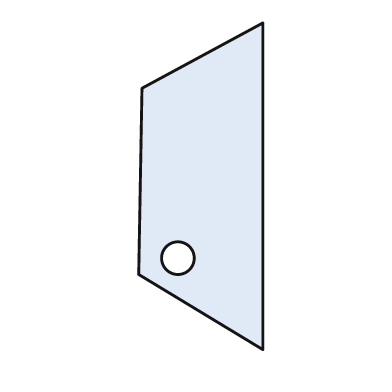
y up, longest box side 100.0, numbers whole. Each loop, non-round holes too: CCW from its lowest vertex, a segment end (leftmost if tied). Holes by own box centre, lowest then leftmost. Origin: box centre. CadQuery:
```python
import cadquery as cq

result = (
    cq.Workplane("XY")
    .moveTo(19.0, -50.0)
    .lineTo(19.0, 50.0)
    .lineTo(-18.0, 30.0)
    .lineTo(-19.0, -27.0)
    .close()
    .moveTo(-7.0, -22.0)
    .circle(5.0)
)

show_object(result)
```